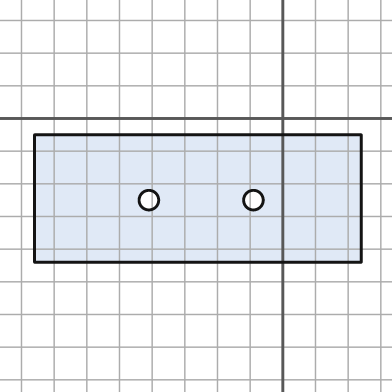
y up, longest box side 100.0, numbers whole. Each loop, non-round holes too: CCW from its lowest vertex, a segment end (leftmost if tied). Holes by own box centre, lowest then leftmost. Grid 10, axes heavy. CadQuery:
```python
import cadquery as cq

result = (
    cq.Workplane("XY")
    .moveTo(-76.0, -44.0)
    .lineTo(24.0, -44.0)
    .lineTo(24.0, -5.0)
    .lineTo(-76.0, -5.0)
    .close()
    .moveTo(-41.0, -25.0)
    .circle(3.0)
    .moveTo(-9.0, -25.0)
    .circle(3.0)
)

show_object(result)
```